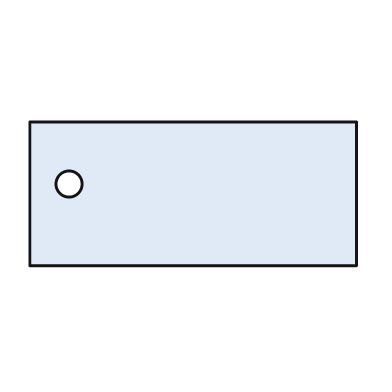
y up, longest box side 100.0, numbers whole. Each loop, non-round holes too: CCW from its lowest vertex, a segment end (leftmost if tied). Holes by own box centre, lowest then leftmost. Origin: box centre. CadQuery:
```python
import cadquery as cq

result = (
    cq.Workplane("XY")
    .moveTo(-50.0, -22.0)
    .lineTo(50.0, -22.0)
    .lineTo(50.0, 22.0)
    .lineTo(-50.0, 22.0)
    .close()
    .moveTo(-38.0, 3.0)
    .circle(4.0)
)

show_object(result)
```